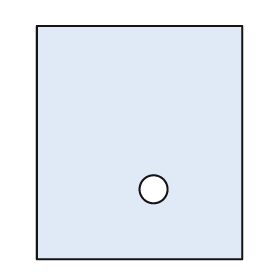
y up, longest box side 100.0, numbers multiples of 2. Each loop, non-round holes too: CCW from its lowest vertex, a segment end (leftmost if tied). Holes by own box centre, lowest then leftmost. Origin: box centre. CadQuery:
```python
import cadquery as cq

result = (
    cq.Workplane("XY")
    .moveTo(-44.0, -50.0)
    .lineTo(44.0, -50.0)
    .lineTo(44.0, 50.0)
    .lineTo(-44.0, 50.0)
    .close()
    .moveTo(6.0, -20.0)
    .circle(6.0)
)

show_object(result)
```